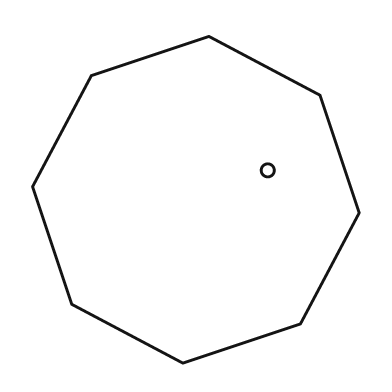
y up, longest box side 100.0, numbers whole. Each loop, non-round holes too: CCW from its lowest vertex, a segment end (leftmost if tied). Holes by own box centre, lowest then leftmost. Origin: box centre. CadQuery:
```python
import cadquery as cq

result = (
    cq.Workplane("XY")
    .moveTo(-4.0, -50.0)
    .lineTo(32.0, -38.0)
    .lineTo(50.0, -4.0)
    .lineTo(38.0, 32.0)
    .lineTo(4.0, 50.0)
    .lineTo(-32.0, 38.0)
    .lineTo(-50.0, 4.0)
    .lineTo(-38.0, -32.0)
    .close()
    .moveTo(22.0, 9.0)
    .circle(2.0)
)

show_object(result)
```